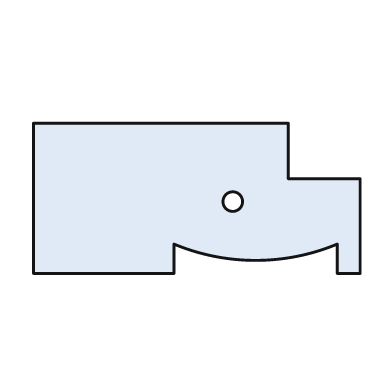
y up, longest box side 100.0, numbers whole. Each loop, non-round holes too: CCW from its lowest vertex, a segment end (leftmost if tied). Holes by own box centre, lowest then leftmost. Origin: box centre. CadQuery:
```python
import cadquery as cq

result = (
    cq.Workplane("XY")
    .moveTo(-50.0, -23.0)
    .lineTo(-7.0, -23.0)
    .lineTo(-7.0, -14.0)
    .threePointArc((18.0, -19.0), (43.0, -14.0))
    .lineTo(43.0, -23.0)
    .lineTo(50.0, -23.0)
    .lineTo(50.0, 6.0)
    .lineTo(28.0, 6.0)
    .lineTo(28.0, 23.0)
    .lineTo(-50.0, 23.0)
    .close()
    .moveTo(11.0, -1.0)
    .circle(3.0)
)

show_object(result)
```